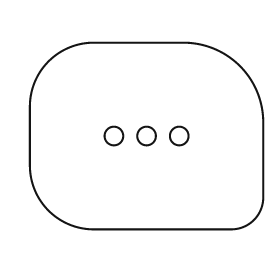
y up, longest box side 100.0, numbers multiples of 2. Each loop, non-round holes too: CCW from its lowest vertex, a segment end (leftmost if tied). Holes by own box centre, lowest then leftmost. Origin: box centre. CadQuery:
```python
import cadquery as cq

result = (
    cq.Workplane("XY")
    .moveTo(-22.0, -40.0)
    .lineTo(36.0, -40.0)
    .threePointArc((46.0, -36.0), (50.0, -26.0))
    .lineTo(50.0, 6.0)
    .threePointArc((40.0, 30.0), (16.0, 40.0))
    .lineTo(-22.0, 40.0)
    .threePointArc((-42.0, 32.0), (-50.0, 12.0))
    .lineTo(-50.0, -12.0)
    .threePointArc((-42.0, -32.0), (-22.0, -40.0))
    .close()
    .moveTo(-14.0, 0.0)
    .circle(4.0)
    .moveTo(0.0, 0.0)
    .circle(4.0)
    .moveTo(14.0, 0.0)
    .circle(4.0)
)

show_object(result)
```